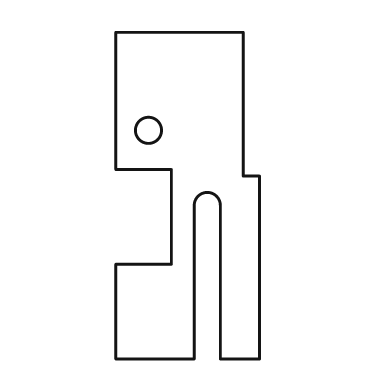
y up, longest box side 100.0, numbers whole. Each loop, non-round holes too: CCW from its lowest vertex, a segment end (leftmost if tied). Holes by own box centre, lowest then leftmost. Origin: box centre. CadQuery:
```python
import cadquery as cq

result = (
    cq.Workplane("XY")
    .moveTo(-22.0, -50.0)
    .lineTo(2.0, -50.0)
    .lineTo(2.0, -3.0)
    .threePointArc((6.0, 1.0), (10.0, -3.0))
    .lineTo(10.0, -50.0)
    .lineTo(22.0, -50.0)
    .lineTo(22.0, 6.0)
    .lineTo(17.0, 6.0)
    .lineTo(17.0, 50.0)
    .lineTo(-22.0, 50.0)
    .lineTo(-22.0, 8.0)
    .lineTo(-5.0, 8.0)
    .lineTo(-5.0, -21.0)
    .lineTo(-22.0, -21.0)
    .close()
    .moveTo(-12.0, 20.0)
    .circle(4.0)
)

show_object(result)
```